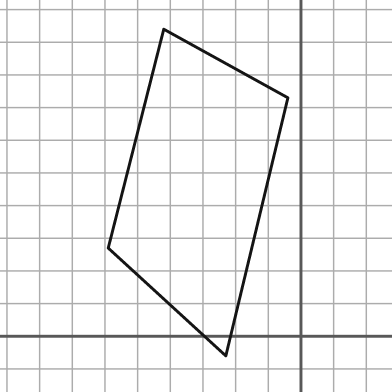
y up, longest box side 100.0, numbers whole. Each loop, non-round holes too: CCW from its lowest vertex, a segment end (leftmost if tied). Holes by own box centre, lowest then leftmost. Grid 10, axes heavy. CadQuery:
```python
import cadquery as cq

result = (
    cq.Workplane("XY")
    .moveTo(-23.0, -6.0)
    .lineTo(-4.0, 73.0)
    .lineTo(-42.0, 94.0)
    .lineTo(-59.0, 27.0)
    .close()
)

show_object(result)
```